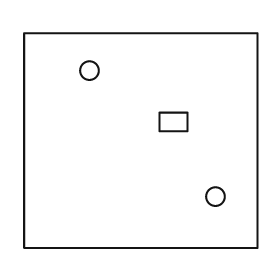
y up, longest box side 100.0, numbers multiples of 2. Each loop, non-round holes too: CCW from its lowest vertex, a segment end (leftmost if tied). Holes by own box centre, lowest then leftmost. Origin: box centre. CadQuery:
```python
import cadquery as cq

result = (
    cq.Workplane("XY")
    .moveTo(-50.0, -46.0)
    .lineTo(50.0, -46.0)
    .lineTo(50.0, 46.0)
    .lineTo(-50.0, 46.0)
    .close()
    .moveTo(32.0, -24.0)
    .circle(4.0)
    .moveTo(8.0, 4.0)
    .lineTo(20.0, 4.0)
    .lineTo(20.0, 12.0)
    .lineTo(8.0, 12.0)
    .close()
    .moveTo(-22.0, 30.0)
    .circle(4.0)
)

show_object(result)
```